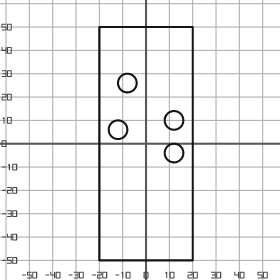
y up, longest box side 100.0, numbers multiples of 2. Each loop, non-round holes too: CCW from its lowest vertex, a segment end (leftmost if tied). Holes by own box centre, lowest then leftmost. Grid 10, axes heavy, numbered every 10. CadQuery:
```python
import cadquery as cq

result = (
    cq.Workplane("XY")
    .moveTo(-20.0, -50.0)
    .lineTo(20.0, -50.0)
    .lineTo(20.0, 50.0)
    .lineTo(-20.0, 50.0)
    .close()
    .moveTo(12.0, -4.0)
    .circle(4.0)
    .moveTo(-12.0, 6.0)
    .circle(4.0)
    .moveTo(12.0, 10.0)
    .circle(4.0)
    .moveTo(-8.0, 26.0)
    .circle(4.0)
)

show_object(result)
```